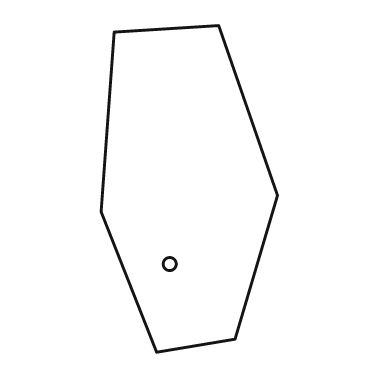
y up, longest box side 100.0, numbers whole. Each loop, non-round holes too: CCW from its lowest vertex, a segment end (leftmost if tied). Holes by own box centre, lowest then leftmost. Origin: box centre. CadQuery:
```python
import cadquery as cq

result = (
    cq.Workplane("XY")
    .moveTo(-10.0, -50.0)
    .lineTo(14.0, -46.0)
    .lineTo(27.0, -2.0)
    .lineTo(9.0, 50.0)
    .lineTo(-23.0, 48.0)
    .lineTo(-27.0, -7.0)
    .close()
    .moveTo(-6.0, -23.0)
    .circle(2.0)
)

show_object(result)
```